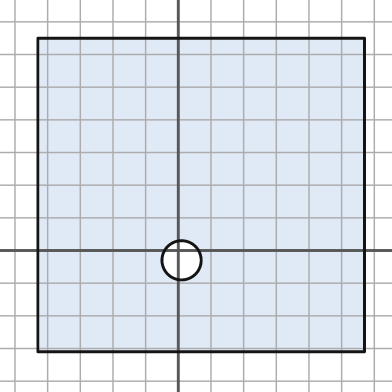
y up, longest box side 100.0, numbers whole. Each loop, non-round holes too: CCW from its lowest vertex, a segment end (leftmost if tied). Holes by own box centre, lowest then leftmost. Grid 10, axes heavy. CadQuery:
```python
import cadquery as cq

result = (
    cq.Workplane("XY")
    .moveTo(-43.0, -31.0)
    .lineTo(57.0, -31.0)
    .lineTo(57.0, 65.0)
    .lineTo(-43.0, 65.0)
    .close()
    .moveTo(1.0, -3.0)
    .circle(6.0)
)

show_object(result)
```